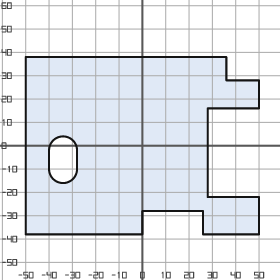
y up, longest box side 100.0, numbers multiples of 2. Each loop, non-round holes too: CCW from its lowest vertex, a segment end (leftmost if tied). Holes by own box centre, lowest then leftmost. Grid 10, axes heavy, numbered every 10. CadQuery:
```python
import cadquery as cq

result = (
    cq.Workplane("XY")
    .moveTo(-50.0, -38.0)
    .lineTo(0.0, -38.0)
    .lineTo(0.0, -28.0)
    .lineTo(26.0, -28.0)
    .lineTo(26.0, -38.0)
    .lineTo(50.0, -38.0)
    .lineTo(50.0, -22.0)
    .lineTo(28.0, -22.0)
    .lineTo(28.0, 16.0)
    .lineTo(50.0, 16.0)
    .lineTo(50.0, 28.0)
    .lineTo(36.0, 28.0)
    .lineTo(36.0, 38.0)
    .lineTo(-50.0, 38.0)
    .close()
    .moveTo(-40.0, -10.0)
    .threePointArc((-34.0, -16.0), (-28.0, -10.0))
    .lineTo(-28.0, -2.0)
    .threePointArc((-34.0, 4.0), (-40.0, -2.0))
    .close()
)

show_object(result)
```